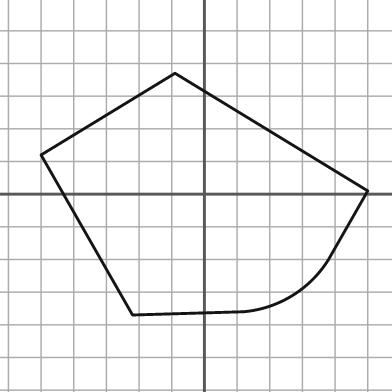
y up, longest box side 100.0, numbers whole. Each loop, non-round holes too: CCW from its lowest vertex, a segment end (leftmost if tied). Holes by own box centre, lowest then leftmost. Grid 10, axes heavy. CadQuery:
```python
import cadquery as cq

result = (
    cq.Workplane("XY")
    .moveTo(-22.0, -37.0)
    .lineTo(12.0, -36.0)
    .threePointArc((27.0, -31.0), (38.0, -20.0))
    .lineTo(50.0, 1.0)
    .lineTo(-9.0, 37.0)
    .lineTo(-50.0, 12.0)
    .close()
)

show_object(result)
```